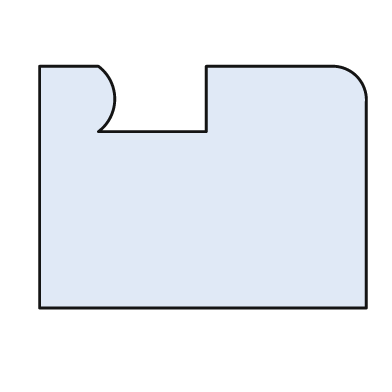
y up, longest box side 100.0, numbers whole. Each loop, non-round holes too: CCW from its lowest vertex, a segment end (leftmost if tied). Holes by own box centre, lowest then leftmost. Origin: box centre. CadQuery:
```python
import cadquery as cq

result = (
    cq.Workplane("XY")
    .moveTo(-50.0, -37.0)
    .lineTo(50.0, -37.0)
    .lineTo(50.0, 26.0)
    .threePointArc((47.0, 34.0), (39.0, 37.0))
    .lineTo(1.0, 37.0)
    .lineTo(1.0, 17.0)
    .lineTo(-32.0, 17.0)
    .threePointArc((-27.0, 27.0), (-32.0, 37.0))
    .lineTo(-50.0, 37.0)
    .close()
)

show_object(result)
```